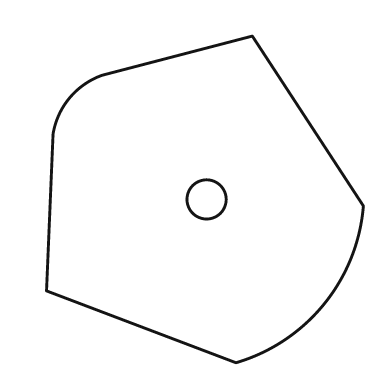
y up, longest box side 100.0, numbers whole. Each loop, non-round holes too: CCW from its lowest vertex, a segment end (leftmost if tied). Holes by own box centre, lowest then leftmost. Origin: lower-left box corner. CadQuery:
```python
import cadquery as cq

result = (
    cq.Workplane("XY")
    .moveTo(58.0, 0.0)
    .threePointArc((85.0, 18.0), (97.0, 48.0))
    .lineTo(63.0, 100.0)
    .lineTo(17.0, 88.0)
    .threePointArc((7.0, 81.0), (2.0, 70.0))
    .lineTo(0.0, 22.0)
    .close()
    .moveTo(49.0, 50.0)
    .circle(6.0)
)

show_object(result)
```